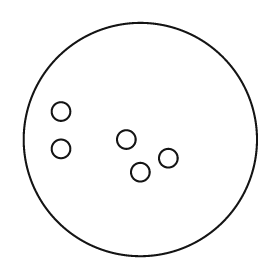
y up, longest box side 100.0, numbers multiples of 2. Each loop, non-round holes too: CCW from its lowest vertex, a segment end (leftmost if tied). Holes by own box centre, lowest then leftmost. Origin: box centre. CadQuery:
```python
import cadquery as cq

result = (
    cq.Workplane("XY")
    .moveTo(0.0, 0.0)
    .circle(50.0)
    .moveTo(0.0, -14.0)
    .circle(4.0)
    .moveTo(12.0, -8.0)
    .circle(4.0)
    .moveTo(-34.0, -4.0)
    .circle(4.0)
    .moveTo(-6.0, 0.0)
    .circle(4.0)
    .moveTo(-34.0, 12.0)
    .circle(4.0)
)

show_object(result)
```